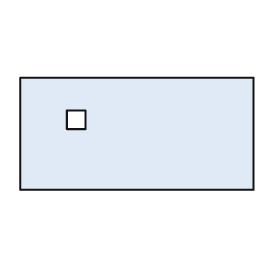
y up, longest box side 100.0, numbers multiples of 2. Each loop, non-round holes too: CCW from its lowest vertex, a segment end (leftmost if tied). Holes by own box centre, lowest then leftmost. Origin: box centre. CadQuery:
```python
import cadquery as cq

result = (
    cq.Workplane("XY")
    .moveTo(-50.0, -24.0)
    .lineTo(50.0, -24.0)
    .lineTo(50.0, 24.0)
    .lineTo(-50.0, 24.0)
    .close()
    .moveTo(-30.0, 2.0)
    .lineTo(-22.0, 2.0)
    .lineTo(-22.0, 10.0)
    .lineTo(-30.0, 10.0)
    .close()
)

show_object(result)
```